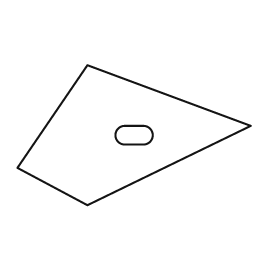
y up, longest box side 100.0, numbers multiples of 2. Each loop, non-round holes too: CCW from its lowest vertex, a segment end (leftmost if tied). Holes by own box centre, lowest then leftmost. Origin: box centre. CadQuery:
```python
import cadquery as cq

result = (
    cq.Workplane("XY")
    .moveTo(-20.0, -30.0)
    .lineTo(50.0, 4.0)
    .lineTo(-20.0, 30.0)
    .lineTo(-50.0, -14.0)
    .close()
    .moveTo(-4.0, -4.0)
    .lineTo(4.0, -4.0)
    .threePointArc((8.0, 0.0), (4.0, 4.0))
    .lineTo(-4.0, 4.0)
    .threePointArc((-8.0, 0.0), (-4.0, -4.0))
    .close()
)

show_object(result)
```